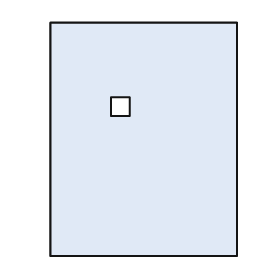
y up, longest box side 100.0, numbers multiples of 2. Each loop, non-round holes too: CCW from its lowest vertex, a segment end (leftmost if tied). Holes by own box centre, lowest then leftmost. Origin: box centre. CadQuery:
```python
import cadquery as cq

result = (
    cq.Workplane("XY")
    .moveTo(-40.0, -50.0)
    .lineTo(40.0, -50.0)
    .lineTo(40.0, 50.0)
    .lineTo(-40.0, 50.0)
    .close()
    .moveTo(-14.0, 10.0)
    .lineTo(-6.0, 10.0)
    .lineTo(-6.0, 18.0)
    .lineTo(-14.0, 18.0)
    .close()
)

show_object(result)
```